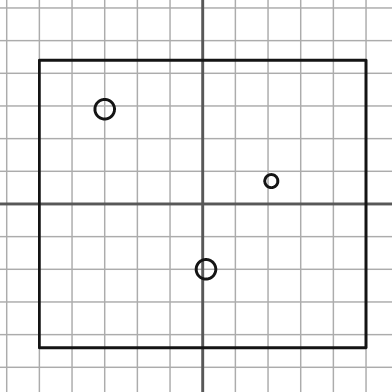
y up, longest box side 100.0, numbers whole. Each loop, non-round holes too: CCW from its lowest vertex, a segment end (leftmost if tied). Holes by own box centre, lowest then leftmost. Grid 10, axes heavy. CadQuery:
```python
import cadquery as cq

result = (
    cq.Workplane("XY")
    .moveTo(-50.0, -44.0)
    .lineTo(50.0, -44.0)
    .lineTo(50.0, 44.0)
    .lineTo(-50.0, 44.0)
    .close()
    .moveTo(1.0, -20.0)
    .circle(3.0)
    .moveTo(21.0, 7.0)
    .circle(2.0)
    .moveTo(-30.0, 29.0)
    .circle(3.0)
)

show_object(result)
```